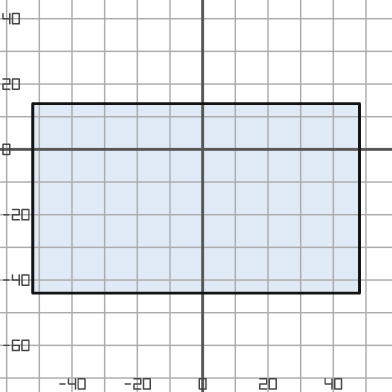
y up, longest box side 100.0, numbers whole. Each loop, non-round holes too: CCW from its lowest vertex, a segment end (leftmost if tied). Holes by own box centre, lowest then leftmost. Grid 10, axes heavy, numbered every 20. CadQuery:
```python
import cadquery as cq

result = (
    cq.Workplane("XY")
    .moveTo(-52.0, -44.0)
    .lineTo(48.0, -44.0)
    .lineTo(48.0, 14.0)
    .lineTo(-52.0, 14.0)
    .close()
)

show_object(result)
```